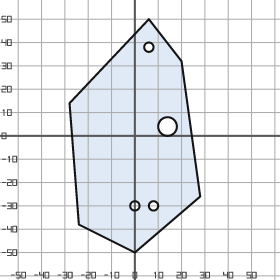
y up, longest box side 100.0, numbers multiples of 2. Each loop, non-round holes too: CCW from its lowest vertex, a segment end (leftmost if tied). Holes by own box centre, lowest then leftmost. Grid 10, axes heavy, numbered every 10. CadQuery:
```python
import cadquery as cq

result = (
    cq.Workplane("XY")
    .moveTo(0.0, -50.0)
    .lineTo(28.0, -26.0)
    .lineTo(20.0, 32.0)
    .lineTo(6.0, 50.0)
    .lineTo(-28.0, 14.0)
    .lineTo(-24.0, -38.0)
    .close()
    .moveTo(0.0, -30.0)
    .circle(2.0)
    .moveTo(8.0, -30.0)
    .circle(2.0)
    .moveTo(14.0, 4.0)
    .circle(4.0)
    .moveTo(6.0, 38.0)
    .circle(2.0)
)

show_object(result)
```